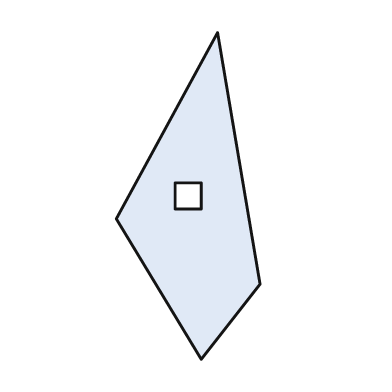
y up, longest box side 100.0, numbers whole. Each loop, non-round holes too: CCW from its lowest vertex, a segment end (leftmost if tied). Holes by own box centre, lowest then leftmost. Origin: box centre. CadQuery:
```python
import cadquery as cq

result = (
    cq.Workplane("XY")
    .moveTo(4.0, -50.0)
    .lineTo(22.0, -27.0)
    .lineTo(9.0, 50.0)
    .lineTo(-22.0, -7.0)
    .close()
    .moveTo(-4.0, -4.0)
    .lineTo(4.0, -4.0)
    .lineTo(4.0, 4.0)
    .lineTo(-4.0, 4.0)
    .close()
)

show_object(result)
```